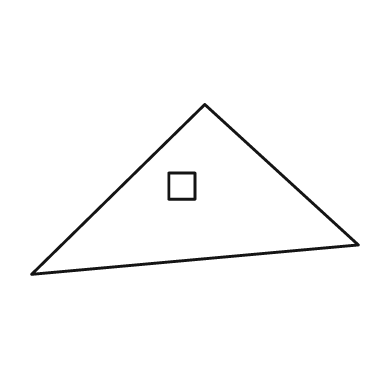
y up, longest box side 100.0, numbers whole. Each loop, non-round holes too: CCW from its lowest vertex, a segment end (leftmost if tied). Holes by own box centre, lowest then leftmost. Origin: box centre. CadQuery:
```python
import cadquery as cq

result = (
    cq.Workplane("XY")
    .moveTo(-50.0, -26.0)
    .lineTo(50.0, -17.0)
    .lineTo(3.0, 26.0)
    .close()
    .moveTo(-8.0, -3.0)
    .lineTo(0.0, -3.0)
    .lineTo(0.0, 5.0)
    .lineTo(-8.0, 5.0)
    .close()
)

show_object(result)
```